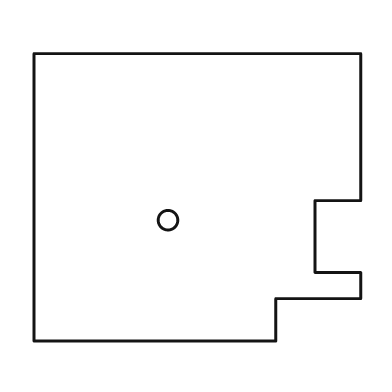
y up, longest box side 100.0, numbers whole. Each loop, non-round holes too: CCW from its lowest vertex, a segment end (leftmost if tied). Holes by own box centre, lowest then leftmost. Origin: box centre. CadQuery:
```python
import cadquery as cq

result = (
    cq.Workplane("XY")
    .moveTo(-50.0, -44.0)
    .lineTo(24.0, -44.0)
    .lineTo(24.0, -31.0)
    .lineTo(50.0, -31.0)
    .lineTo(50.0, -23.0)
    .lineTo(36.0, -23.0)
    .lineTo(36.0, -1.0)
    .lineTo(50.0, -1.0)
    .lineTo(50.0, 44.0)
    .lineTo(-50.0, 44.0)
    .close()
    .moveTo(-9.0, -7.0)
    .circle(3.0)
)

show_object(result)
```